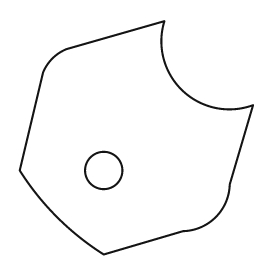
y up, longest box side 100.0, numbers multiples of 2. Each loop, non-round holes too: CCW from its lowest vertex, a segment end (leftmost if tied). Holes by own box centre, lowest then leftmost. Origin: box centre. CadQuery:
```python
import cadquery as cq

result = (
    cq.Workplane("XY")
    .moveTo(-14.0, -50.0)
    .lineTo(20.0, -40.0)
    .threePointArc((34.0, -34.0), (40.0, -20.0))
    .lineTo(50.0, 14.0)
    .threePointArc((20.0, 20.0), (12.0, 50.0))
    .lineTo(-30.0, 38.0)
    .threePointArc((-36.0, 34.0), (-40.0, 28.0))
    .lineTo(-50.0, -14.0)
    .threePointArc((-34.0, -34.0), (-14.0, -50.0))
    .close()
    .moveTo(-14.0, -14.0)
    .circle(8.0)
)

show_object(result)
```